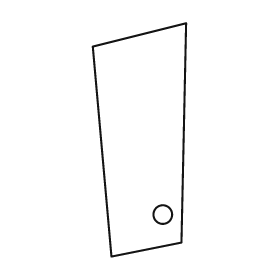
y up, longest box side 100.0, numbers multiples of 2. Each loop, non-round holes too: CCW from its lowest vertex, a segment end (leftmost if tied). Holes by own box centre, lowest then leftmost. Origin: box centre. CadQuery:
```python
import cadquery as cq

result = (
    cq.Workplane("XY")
    .moveTo(-12.0, -50.0)
    .lineTo(18.0, -44.0)
    .lineTo(20.0, 50.0)
    .lineTo(-20.0, 40.0)
    .close()
    .moveTo(10.0, -32.0)
    .circle(4.0)
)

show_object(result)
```